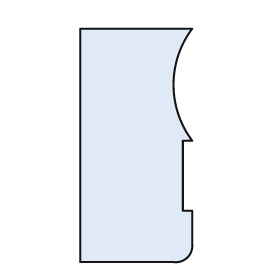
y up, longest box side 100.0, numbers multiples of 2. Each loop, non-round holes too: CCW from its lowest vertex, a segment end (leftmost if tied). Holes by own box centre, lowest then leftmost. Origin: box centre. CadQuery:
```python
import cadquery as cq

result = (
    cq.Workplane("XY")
    .moveTo(-24.0, -50.0)
    .lineTo(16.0, -50.0)
    .threePointArc((22.0, -48.0), (24.0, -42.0))
    .lineTo(24.0, -28.0)
    .lineTo(20.0, -28.0)
    .lineTo(20.0, 2.0)
    .lineTo(24.0, 2.0)
    .threePointArc((16.0, 26.0), (24.0, 50.0))
    .lineTo(-24.0, 50.0)
    .close()
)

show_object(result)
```